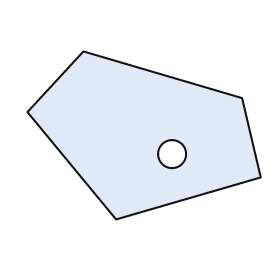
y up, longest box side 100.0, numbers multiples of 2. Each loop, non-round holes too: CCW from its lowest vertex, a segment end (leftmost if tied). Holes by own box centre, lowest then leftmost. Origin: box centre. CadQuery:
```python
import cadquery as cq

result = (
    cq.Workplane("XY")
    .moveTo(-12.0, -36.0)
    .lineTo(50.0, -18.0)
    .lineTo(42.0, 16.0)
    .lineTo(-26.0, 36.0)
    .lineTo(-50.0, 10.0)
    .close()
    .moveTo(12.0, -8.0)
    .circle(6.0)
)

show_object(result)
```